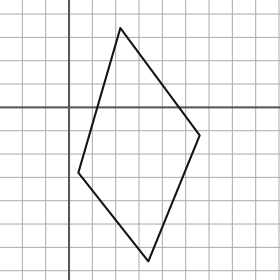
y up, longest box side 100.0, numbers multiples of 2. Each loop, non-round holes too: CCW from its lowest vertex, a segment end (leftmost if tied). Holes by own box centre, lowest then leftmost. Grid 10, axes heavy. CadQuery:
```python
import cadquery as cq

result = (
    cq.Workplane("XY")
    .moveTo(34.0, -66.0)
    .lineTo(56.0, -12.0)
    .lineTo(22.0, 34.0)
    .lineTo(4.0, -28.0)
    .close()
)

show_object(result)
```